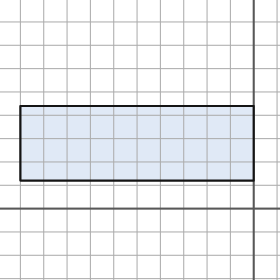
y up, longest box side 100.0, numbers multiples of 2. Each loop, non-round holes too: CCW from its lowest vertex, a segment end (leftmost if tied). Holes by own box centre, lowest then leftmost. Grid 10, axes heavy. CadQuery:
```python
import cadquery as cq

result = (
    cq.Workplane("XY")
    .moveTo(-100.0, 12.0)
    .lineTo(0.0, 12.0)
    .lineTo(0.0, 44.0)
    .lineTo(-100.0, 44.0)
    .close()
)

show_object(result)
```